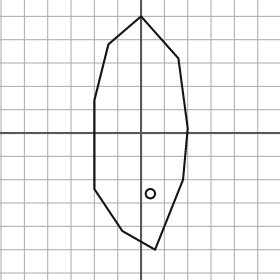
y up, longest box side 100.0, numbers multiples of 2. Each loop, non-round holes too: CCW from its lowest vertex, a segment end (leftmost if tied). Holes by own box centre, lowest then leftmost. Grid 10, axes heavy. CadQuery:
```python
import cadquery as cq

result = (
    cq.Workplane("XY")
    .moveTo(6.0, -50.0)
    .lineTo(18.0, -20.0)
    .lineTo(20.0, 2.0)
    .lineTo(16.0, 32.0)
    .lineTo(0.0, 50.0)
    .lineTo(-14.0, 38.0)
    .lineTo(-20.0, 14.0)
    .lineTo(-20.0, -24.0)
    .lineTo(-8.0, -42.0)
    .close()
    .moveTo(4.0, -26.0)
    .circle(2.0)
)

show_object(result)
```